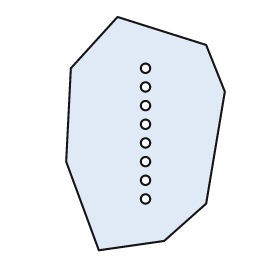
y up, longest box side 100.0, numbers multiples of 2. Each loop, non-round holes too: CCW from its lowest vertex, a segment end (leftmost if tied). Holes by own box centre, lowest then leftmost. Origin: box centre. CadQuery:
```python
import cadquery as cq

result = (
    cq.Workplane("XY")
    .moveTo(-20.0, -50.0)
    .lineTo(8.0, -46.0)
    .lineTo(26.0, -30.0)
    .lineTo(34.0, 18.0)
    .lineTo(26.0, 38.0)
    .lineTo(-12.0, 50.0)
    .lineTo(-32.0, 28.0)
    .lineTo(-34.0, -12.0)
    .close()
    .moveTo(0.0, -28.0)
    .circle(2.0)
    .moveTo(0.0, -20.0)
    .circle(2.0)
    .moveTo(0.0, -12.0)
    .circle(2.0)
    .moveTo(0.0, -4.0)
    .circle(2.0)
    .moveTo(0.0, 4.0)
    .circle(2.0)
    .moveTo(0.0, 12.0)
    .circle(2.0)
    .moveTo(0.0, 20.0)
    .circle(2.0)
    .moveTo(0.0, 28.0)
    .circle(2.0)
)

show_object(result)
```